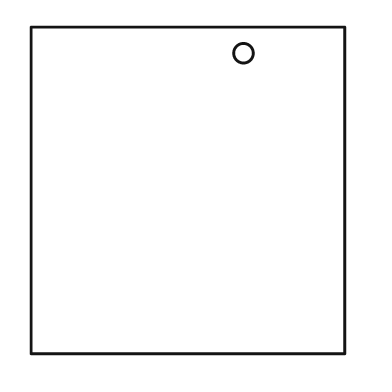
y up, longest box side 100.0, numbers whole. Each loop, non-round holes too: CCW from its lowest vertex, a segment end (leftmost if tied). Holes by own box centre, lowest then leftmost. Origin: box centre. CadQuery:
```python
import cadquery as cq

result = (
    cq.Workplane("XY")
    .moveTo(-48.0, -50.0)
    .lineTo(48.0, -50.0)
    .lineTo(48.0, 50.0)
    .lineTo(-48.0, 50.0)
    .close()
    .moveTo(17.0, 42.0)
    .circle(3.0)
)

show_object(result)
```